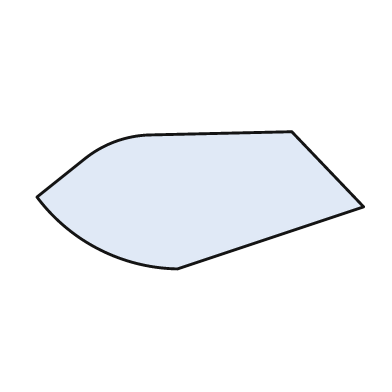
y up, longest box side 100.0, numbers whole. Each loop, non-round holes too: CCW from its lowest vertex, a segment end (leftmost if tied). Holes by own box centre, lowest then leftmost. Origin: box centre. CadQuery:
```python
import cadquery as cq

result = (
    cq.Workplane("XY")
    .moveTo(-7.0, -21.0)
    .lineTo(50.0, -2.0)
    .lineTo(28.0, 21.0)
    .lineTo(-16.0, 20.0)
    .threePointArc((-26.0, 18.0), (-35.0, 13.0))
    .lineTo(-50.0, 1.0)
    .threePointArc((-31.0, -15.0), (-7.0, -21.0))
    .close()
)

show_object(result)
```